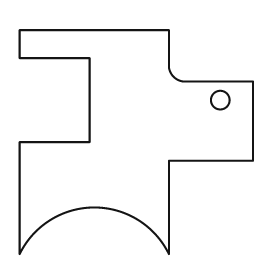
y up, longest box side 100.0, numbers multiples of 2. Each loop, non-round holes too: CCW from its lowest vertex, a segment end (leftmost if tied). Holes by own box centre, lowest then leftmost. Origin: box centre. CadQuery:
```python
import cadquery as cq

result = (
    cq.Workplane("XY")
    .moveTo(-50.0, -48.0)
    .threePointArc((-18.0, -28.0), (14.0, -48.0))
    .lineTo(14.0, -8.0)
    .lineTo(50.0, -8.0)
    .lineTo(50.0, 26.0)
    .lineTo(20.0, 26.0)
    .threePointArc((16.0, 28.0), (14.0, 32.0))
    .lineTo(14.0, 48.0)
    .lineTo(-50.0, 48.0)
    .lineTo(-50.0, 36.0)
    .lineTo(-20.0, 36.0)
    .lineTo(-20.0, 0.0)
    .lineTo(-50.0, 0.0)
    .close()
    .moveTo(36.0, 18.0)
    .circle(4.0)
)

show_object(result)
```